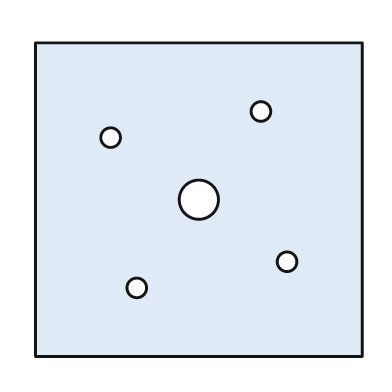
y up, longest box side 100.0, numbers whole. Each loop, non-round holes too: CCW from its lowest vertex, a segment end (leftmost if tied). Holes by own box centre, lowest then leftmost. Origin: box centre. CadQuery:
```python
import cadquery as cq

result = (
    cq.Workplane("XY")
    .moveTo(-50.0, -48.0)
    .lineTo(50.0, -48.0)
    .lineTo(50.0, 48.0)
    .lineTo(-50.0, 48.0)
    .close()
    .moveTo(-19.0, -27.0)
    .circle(3.0)
    .moveTo(27.0, -19.0)
    .circle(3.0)
    .moveTo(0.0, 0.0)
    .circle(6.0)
    .moveTo(-27.0, 19.0)
    .circle(3.0)
    .moveTo(19.0, 27.0)
    .circle(3.0)
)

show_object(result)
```